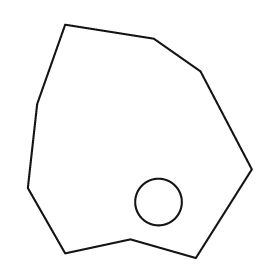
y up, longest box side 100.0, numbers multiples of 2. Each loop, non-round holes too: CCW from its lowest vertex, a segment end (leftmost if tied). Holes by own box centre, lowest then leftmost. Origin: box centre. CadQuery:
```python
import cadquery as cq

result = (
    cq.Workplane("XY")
    .moveTo(24.0, -50.0)
    .lineTo(48.0, -12.0)
    .lineTo(26.0, 30.0)
    .lineTo(6.0, 44.0)
    .lineTo(-32.0, 50.0)
    .lineTo(-44.0, 16.0)
    .lineTo(-48.0, -20.0)
    .lineTo(-32.0, -48.0)
    .lineTo(-4.0, -42.0)
    .close()
    .moveTo(8.0, -26.0)
    .circle(10.0)
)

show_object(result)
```